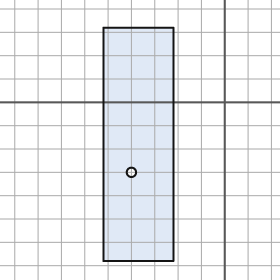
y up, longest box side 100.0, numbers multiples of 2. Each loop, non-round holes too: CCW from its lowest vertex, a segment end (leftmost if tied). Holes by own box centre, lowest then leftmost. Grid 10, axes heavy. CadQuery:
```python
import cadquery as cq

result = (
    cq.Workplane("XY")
    .moveTo(-52.0, -68.0)
    .lineTo(-22.0, -68.0)
    .lineTo(-22.0, 32.0)
    .lineTo(-52.0, 32.0)
    .close()
    .moveTo(-40.0, -30.0)
    .circle(2.0)
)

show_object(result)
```